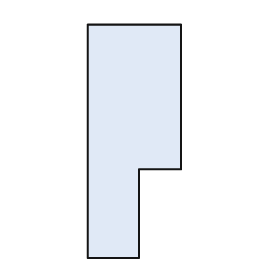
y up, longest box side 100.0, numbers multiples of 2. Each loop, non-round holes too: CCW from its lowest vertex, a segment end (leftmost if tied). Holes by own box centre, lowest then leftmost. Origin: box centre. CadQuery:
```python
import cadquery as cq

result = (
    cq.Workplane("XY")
    .moveTo(-20.0, -50.0)
    .lineTo(2.0, -50.0)
    .lineTo(2.0, -12.0)
    .lineTo(20.0, -12.0)
    .lineTo(20.0, 50.0)
    .lineTo(-20.0, 50.0)
    .close()
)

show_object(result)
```